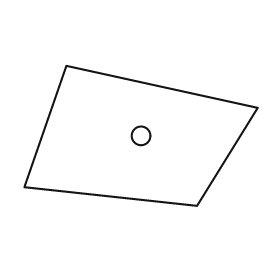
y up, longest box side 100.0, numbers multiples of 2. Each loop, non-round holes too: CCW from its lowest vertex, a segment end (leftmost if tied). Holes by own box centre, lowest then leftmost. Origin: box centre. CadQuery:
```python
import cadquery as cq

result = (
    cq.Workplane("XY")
    .moveTo(24.0, -30.0)
    .lineTo(50.0, 12.0)
    .lineTo(-32.0, 30.0)
    .lineTo(-50.0, -22.0)
    .close()
    .moveTo(0.0, 0.0)
    .circle(4.0)
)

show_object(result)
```